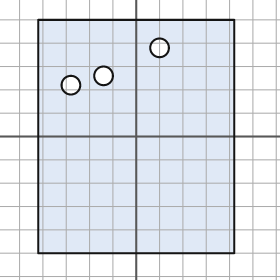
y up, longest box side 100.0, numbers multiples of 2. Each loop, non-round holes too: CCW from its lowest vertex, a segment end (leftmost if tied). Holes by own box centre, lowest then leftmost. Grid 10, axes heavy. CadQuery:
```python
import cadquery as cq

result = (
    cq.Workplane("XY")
    .moveTo(-42.0, -50.0)
    .lineTo(42.0, -50.0)
    .lineTo(42.0, 50.0)
    .lineTo(-42.0, 50.0)
    .close()
    .moveTo(-28.0, 22.0)
    .circle(4.0)
    .moveTo(-14.0, 26.0)
    .circle(4.0)
    .moveTo(10.0, 38.0)
    .circle(4.0)
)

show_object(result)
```